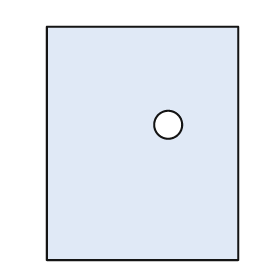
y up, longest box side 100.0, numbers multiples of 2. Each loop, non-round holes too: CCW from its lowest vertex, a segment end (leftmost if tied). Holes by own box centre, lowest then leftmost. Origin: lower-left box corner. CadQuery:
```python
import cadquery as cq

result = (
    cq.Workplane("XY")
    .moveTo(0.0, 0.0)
    .lineTo(82.0, 0.0)
    .lineTo(82.0, 100.0)
    .lineTo(0.0, 100.0)
    .close()
    .moveTo(52.0, 58.0)
    .circle(6.0)
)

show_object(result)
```